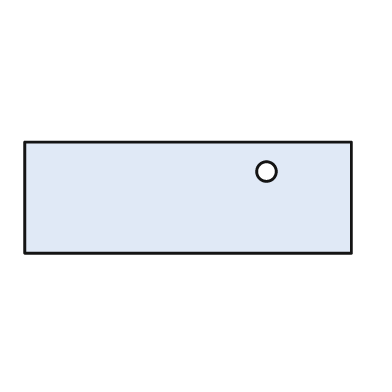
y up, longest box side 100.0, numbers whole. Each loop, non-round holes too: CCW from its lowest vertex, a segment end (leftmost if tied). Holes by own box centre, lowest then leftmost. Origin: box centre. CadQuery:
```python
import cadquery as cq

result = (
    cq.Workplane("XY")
    .moveTo(-50.0, -17.0)
    .lineTo(50.0, -17.0)
    .lineTo(50.0, 17.0)
    .lineTo(-50.0, 17.0)
    .close()
    .moveTo(24.0, 8.0)
    .circle(3.0)
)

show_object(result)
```